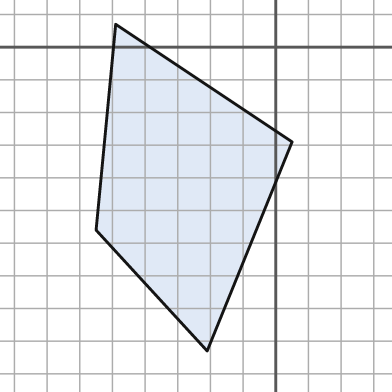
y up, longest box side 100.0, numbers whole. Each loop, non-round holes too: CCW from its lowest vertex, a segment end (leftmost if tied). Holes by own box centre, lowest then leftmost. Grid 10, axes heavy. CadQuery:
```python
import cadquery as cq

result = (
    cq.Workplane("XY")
    .moveTo(-21.0, -93.0)
    .lineTo(5.0, -29.0)
    .lineTo(-49.0, 7.0)
    .lineTo(-55.0, -56.0)
    .close()
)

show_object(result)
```